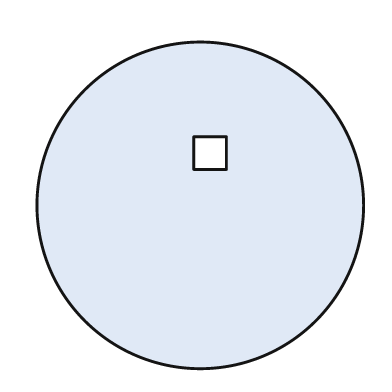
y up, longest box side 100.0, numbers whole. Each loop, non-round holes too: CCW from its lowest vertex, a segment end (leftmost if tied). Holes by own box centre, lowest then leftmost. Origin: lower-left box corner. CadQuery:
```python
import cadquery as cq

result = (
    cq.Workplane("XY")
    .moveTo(50.0, 50.0)
    .circle(50.0)
    .moveTo(48.0, 61.0)
    .lineTo(58.0, 61.0)
    .lineTo(58.0, 71.0)
    .lineTo(48.0, 71.0)
    .close()
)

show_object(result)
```